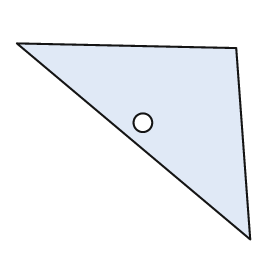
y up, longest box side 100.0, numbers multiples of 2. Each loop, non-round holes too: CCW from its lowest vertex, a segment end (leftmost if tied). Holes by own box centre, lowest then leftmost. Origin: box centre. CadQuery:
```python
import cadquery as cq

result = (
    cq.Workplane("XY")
    .moveTo(50.0, -42.0)
    .lineTo(44.0, 40.0)
    .lineTo(-50.0, 42.0)
    .close()
    .moveTo(4.0, 8.0)
    .circle(4.0)
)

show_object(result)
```